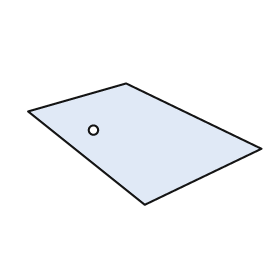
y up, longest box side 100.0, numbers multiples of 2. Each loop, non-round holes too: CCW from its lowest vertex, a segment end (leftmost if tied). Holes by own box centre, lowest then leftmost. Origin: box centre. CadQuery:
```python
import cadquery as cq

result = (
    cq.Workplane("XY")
    .moveTo(0.0, -26.0)
    .lineTo(50.0, -2.0)
    .lineTo(-8.0, 26.0)
    .lineTo(-50.0, 14.0)
    .close()
    .moveTo(-22.0, 6.0)
    .circle(2.0)
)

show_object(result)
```